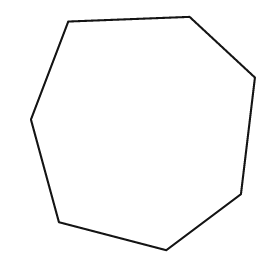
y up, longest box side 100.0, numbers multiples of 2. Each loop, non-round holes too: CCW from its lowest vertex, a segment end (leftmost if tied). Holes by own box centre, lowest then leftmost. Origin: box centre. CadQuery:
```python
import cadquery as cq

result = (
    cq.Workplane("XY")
    .moveTo(10.0, -50.0)
    .lineTo(42.0, -26.0)
    .lineTo(48.0, 24.0)
    .lineTo(20.0, 50.0)
    .lineTo(-32.0, 48.0)
    .lineTo(-48.0, 6.0)
    .lineTo(-36.0, -38.0)
    .close()
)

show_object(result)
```